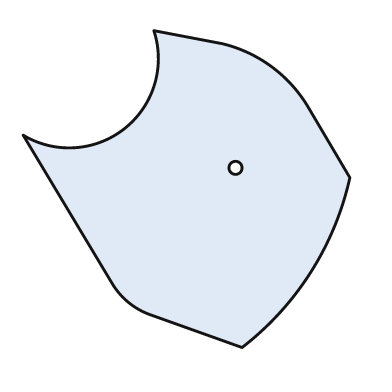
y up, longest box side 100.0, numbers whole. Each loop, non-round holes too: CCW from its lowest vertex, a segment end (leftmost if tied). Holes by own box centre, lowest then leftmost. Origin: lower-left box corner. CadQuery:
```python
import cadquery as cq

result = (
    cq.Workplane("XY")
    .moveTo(67.0, 0.0)
    .threePointArc((88.0, 23.0), (100.0, 52.0))
    .lineTo(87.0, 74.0)
    .threePointArc((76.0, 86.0), (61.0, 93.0))
    .lineTo(40.0, 97.0)
    .threePointArc((31.0, 67.0), (0.0, 65.0))
    .lineTo(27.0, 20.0)
    .threePointArc((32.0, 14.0), (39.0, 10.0))
    .close()
    .moveTo(65.0, 55.0)
    .circle(2.0)
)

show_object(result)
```